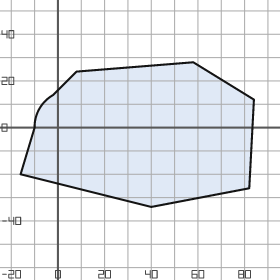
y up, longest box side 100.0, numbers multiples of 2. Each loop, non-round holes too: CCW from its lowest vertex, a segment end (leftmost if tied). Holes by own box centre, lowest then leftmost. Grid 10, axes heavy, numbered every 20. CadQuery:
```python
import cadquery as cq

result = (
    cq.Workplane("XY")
    .moveTo(40.0, -34.0)
    .lineTo(82.0, -26.0)
    .lineTo(84.0, 12.0)
    .lineTo(58.0, 28.0)
    .lineTo(8.0, 24.0)
    .lineTo(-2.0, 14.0)
    .threePointArc((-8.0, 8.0), (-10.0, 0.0))
    .lineTo(-16.0, -20.0)
    .close()
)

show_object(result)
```